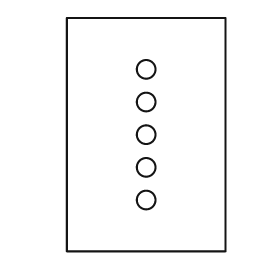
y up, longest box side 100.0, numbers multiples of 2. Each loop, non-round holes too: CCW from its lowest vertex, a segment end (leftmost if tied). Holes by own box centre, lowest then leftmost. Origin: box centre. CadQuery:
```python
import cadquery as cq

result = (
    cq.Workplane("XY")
    .moveTo(-34.0, -50.0)
    .lineTo(34.0, -50.0)
    .lineTo(34.0, 50.0)
    .lineTo(-34.0, 50.0)
    .close()
    .moveTo(0.0, -28.0)
    .circle(4.0)
    .moveTo(0.0, -14.0)
    .circle(4.0)
    .moveTo(0.0, 0.0)
    .circle(4.0)
    .moveTo(0.0, 14.0)
    .circle(4.0)
    .moveTo(0.0, 28.0)
    .circle(4.0)
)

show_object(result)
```